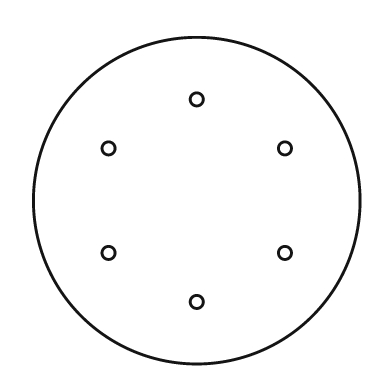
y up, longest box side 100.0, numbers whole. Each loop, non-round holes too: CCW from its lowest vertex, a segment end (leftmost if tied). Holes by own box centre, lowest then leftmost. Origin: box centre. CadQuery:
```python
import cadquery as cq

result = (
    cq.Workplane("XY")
    .moveTo(0.0, 0.0)
    .circle(50.0)
    .moveTo(0.0, -31.0)
    .circle(2.0)
    .moveTo(-27.0, -16.0)
    .circle(2.0)
    .moveTo(27.0, -16.0)
    .circle(2.0)
    .moveTo(-27.0, 16.0)
    .circle(2.0)
    .moveTo(27.0, 16.0)
    .circle(2.0)
    .moveTo(0.0, 31.0)
    .circle(2.0)
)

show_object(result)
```